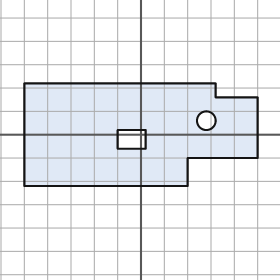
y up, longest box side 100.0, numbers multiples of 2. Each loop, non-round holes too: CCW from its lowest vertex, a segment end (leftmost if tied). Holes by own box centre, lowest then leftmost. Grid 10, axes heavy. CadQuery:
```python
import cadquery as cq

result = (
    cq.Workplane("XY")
    .moveTo(-50.0, -22.0)
    .lineTo(20.0, -22.0)
    .lineTo(20.0, -10.0)
    .lineTo(50.0, -10.0)
    .lineTo(50.0, 16.0)
    .lineTo(32.0, 16.0)
    .lineTo(32.0, 22.0)
    .lineTo(-50.0, 22.0)
    .close()
    .moveTo(-10.0, -6.0)
    .lineTo(2.0, -6.0)
    .lineTo(2.0, 2.0)
    .lineTo(-10.0, 2.0)
    .close()
    .moveTo(28.0, 6.0)
    .circle(4.0)
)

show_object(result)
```